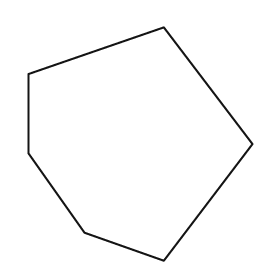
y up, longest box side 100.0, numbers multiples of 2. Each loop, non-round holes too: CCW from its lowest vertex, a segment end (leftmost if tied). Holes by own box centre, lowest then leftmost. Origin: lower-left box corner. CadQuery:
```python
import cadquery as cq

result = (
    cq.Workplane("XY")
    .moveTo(58.0, 0.0)
    .lineTo(96.0, 50.0)
    .lineTo(58.0, 100.0)
    .lineTo(0.0, 80.0)
    .lineTo(0.0, 46.0)
    .lineTo(24.0, 12.0)
    .close()
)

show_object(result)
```